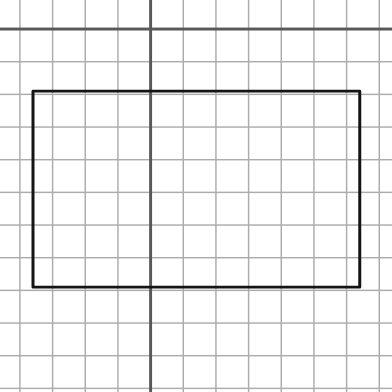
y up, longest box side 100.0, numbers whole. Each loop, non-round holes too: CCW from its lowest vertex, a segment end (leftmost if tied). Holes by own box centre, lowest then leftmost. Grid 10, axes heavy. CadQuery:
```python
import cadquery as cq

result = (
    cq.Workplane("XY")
    .moveTo(-36.0, -79.0)
    .lineTo(64.0, -79.0)
    .lineTo(64.0, -19.0)
    .lineTo(-36.0, -19.0)
    .close()
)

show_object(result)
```